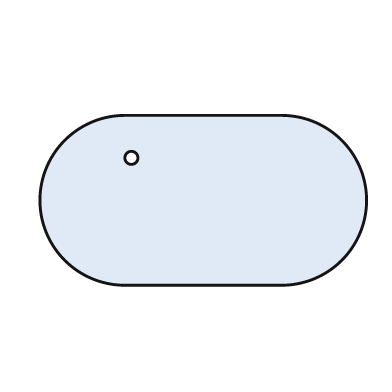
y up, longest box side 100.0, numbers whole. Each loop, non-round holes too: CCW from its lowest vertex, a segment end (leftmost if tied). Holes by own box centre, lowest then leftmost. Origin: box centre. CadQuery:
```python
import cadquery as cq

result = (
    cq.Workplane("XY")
    .moveTo(-24.0, -26.0)
    .lineTo(24.0, -26.0)
    .threePointArc((50.0, 0.0), (24.0, 26.0))
    .lineTo(-24.0, 26.0)
    .threePointArc((-50.0, 0.0), (-24.0, -26.0))
    .close()
    .moveTo(-22.0, 13.0)
    .circle(2.0)
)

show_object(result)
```